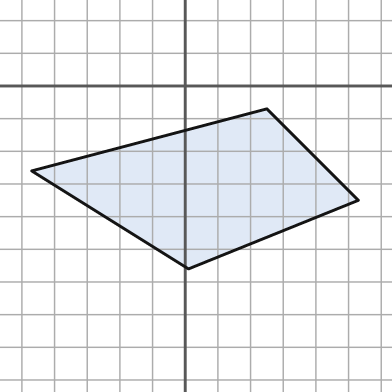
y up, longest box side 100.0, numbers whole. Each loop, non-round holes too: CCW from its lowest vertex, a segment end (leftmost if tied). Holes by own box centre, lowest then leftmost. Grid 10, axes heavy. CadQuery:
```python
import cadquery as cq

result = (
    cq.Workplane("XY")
    .moveTo(1.0, -56.0)
    .lineTo(53.0, -35.0)
    .lineTo(25.0, -7.0)
    .lineTo(-47.0, -26.0)
    .close()
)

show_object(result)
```